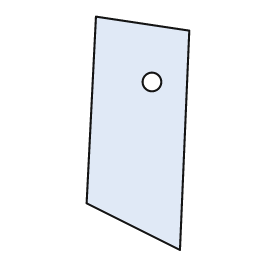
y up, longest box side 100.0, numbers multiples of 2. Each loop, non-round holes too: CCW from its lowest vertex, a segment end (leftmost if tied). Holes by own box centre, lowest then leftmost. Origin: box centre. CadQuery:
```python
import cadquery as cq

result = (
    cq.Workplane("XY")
    .moveTo(18.0, -50.0)
    .lineTo(22.0, 44.0)
    .lineTo(-18.0, 50.0)
    .lineTo(-22.0, -30.0)
    .close()
    .moveTo(6.0, 22.0)
    .circle(4.0)
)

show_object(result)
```